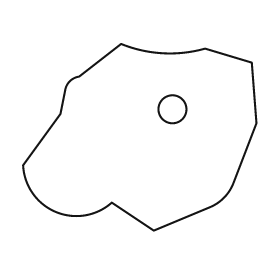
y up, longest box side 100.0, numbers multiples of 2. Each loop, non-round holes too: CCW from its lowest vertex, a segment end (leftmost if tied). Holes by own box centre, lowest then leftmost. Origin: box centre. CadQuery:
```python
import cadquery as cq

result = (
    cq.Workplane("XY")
    .moveTo(6.0, -40.0)
    .lineTo(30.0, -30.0)
    .threePointArc((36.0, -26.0), (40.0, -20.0))
    .lineTo(50.0, 6.0)
    .lineTo(48.0, 32.0)
    .lineTo(28.0, 38.0)
    .threePointArc((10.0, 36.0), (-8.0, 40.0))
    .lineTo(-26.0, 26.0)
    .threePointArc((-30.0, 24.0), (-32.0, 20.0))
    .lineTo(-34.0, 10.0)
    .lineTo(-50.0, -12.0)
    .threePointArc((-36.0, -32.0), (-12.0, -28.0))
    .close()
    .moveTo(14.0, 12.0)
    .circle(6.0)
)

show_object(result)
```